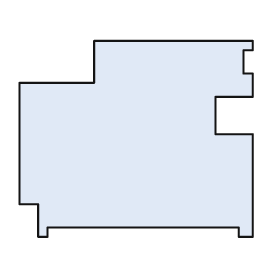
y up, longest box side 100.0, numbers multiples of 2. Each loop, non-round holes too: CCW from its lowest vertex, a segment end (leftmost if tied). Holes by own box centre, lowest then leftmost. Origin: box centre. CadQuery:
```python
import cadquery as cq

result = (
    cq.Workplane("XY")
    .moveTo(-42.0, -42.0)
    .lineTo(-38.0, -42.0)
    .lineTo(-38.0, -38.0)
    .lineTo(44.0, -38.0)
    .lineTo(44.0, -42.0)
    .lineTo(50.0, -42.0)
    .lineTo(50.0, 2.0)
    .lineTo(34.0, 2.0)
    .lineTo(34.0, 18.0)
    .lineTo(50.0, 18.0)
    .lineTo(50.0, 28.0)
    .lineTo(46.0, 28.0)
    .lineTo(46.0, 38.0)
    .lineTo(50.0, 38.0)
    .lineTo(50.0, 42.0)
    .lineTo(-18.0, 42.0)
    .lineTo(-18.0, 24.0)
    .lineTo(-50.0, 24.0)
    .lineTo(-50.0, -28.0)
    .lineTo(-42.0, -28.0)
    .close()
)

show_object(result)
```